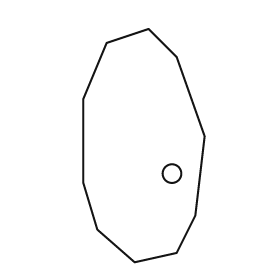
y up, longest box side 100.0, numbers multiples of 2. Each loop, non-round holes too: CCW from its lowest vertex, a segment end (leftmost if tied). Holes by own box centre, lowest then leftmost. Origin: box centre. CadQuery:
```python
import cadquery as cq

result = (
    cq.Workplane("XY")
    .moveTo(-4.0, -50.0)
    .lineTo(14.0, -46.0)
    .lineTo(22.0, -30.0)
    .lineTo(26.0, 4.0)
    .lineTo(14.0, 38.0)
    .lineTo(2.0, 50.0)
    .lineTo(-16.0, 44.0)
    .lineTo(-26.0, 20.0)
    .lineTo(-26.0, -16.0)
    .lineTo(-20.0, -36.0)
    .close()
    .moveTo(12.0, -12.0)
    .circle(4.0)
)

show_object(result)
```